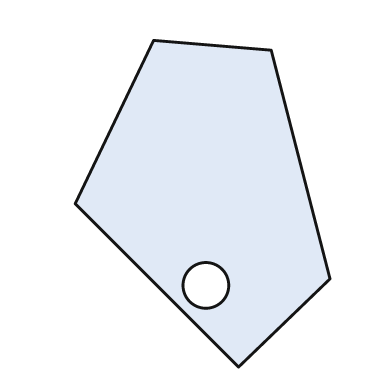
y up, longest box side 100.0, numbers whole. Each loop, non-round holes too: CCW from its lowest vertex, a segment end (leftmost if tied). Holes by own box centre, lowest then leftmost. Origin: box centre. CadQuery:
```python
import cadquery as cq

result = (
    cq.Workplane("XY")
    .moveTo(11.0, -50.0)
    .lineTo(39.0, -23.0)
    .lineTo(21.0, 47.0)
    .lineTo(-15.0, 50.0)
    .lineTo(-39.0, 0.0)
    .close()
    .moveTo(1.0, -25.0)
    .circle(7.0)
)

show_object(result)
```